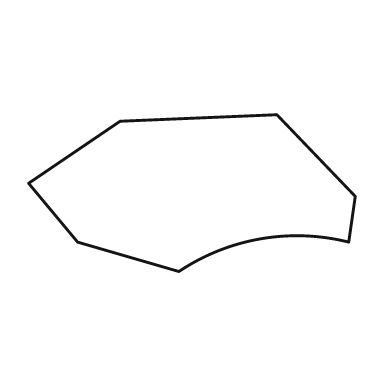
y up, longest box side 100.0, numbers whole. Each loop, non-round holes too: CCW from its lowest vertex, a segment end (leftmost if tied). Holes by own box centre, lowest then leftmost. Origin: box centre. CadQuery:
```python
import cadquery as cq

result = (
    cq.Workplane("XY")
    .moveTo(-4.0, -24.0)
    .threePointArc((21.0, -14.0), (48.0, -15.0))
    .lineTo(50.0, -1.0)
    .lineTo(26.0, 24.0)
    .lineTo(-22.0, 22.0)
    .lineTo(-50.0, 3.0)
    .lineTo(-35.0, -15.0)
    .close()
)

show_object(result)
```